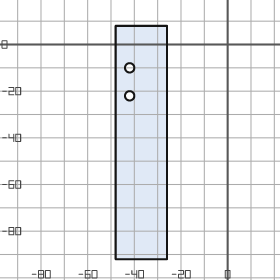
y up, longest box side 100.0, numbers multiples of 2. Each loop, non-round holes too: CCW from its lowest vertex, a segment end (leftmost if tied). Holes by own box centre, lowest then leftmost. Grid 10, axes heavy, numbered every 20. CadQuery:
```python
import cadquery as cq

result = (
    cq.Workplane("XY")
    .moveTo(-48.0, -92.0)
    .lineTo(-26.0, -92.0)
    .lineTo(-26.0, 8.0)
    .lineTo(-48.0, 8.0)
    .close()
    .moveTo(-42.0, -22.0)
    .circle(2.0)
    .moveTo(-42.0, -10.0)
    .circle(2.0)
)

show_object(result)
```